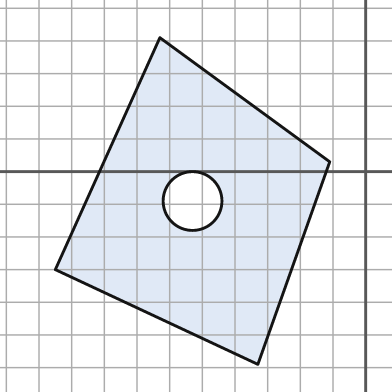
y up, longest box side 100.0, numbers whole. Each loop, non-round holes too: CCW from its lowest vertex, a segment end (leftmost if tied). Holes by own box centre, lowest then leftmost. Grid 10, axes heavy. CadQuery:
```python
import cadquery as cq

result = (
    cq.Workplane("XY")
    .moveTo(-33.0, -59.0)
    .lineTo(-11.0, 3.0)
    .lineTo(-63.0, 41.0)
    .lineTo(-95.0, -30.0)
    .close()
    .moveTo(-53.0, -9.0)
    .circle(9.0)
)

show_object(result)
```